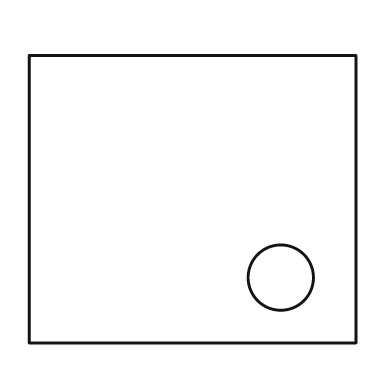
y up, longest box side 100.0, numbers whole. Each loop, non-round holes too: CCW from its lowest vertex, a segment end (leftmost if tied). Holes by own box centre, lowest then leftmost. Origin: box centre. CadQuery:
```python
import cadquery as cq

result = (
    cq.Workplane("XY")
    .moveTo(-50.0, -44.0)
    .lineTo(50.0, -44.0)
    .lineTo(50.0, 44.0)
    .lineTo(-50.0, 44.0)
    .close()
    .moveTo(27.0, -24.0)
    .circle(10.0)
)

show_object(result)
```